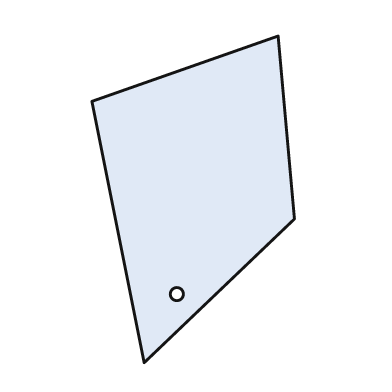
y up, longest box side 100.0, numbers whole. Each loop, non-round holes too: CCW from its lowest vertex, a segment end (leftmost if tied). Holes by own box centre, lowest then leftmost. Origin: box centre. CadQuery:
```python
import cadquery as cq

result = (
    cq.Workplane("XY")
    .moveTo(-15.0, -50.0)
    .lineTo(31.0, -6.0)
    .lineTo(26.0, 50.0)
    .lineTo(-31.0, 30.0)
    .close()
    .moveTo(-5.0, -29.0)
    .circle(2.0)
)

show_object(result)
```